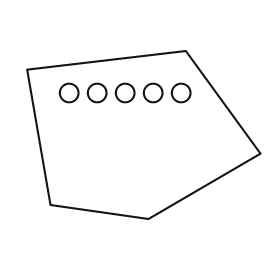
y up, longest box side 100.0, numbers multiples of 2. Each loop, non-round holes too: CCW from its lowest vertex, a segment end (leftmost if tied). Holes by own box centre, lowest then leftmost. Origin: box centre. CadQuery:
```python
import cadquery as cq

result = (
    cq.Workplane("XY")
    .moveTo(2.0, -36.0)
    .lineTo(50.0, -8.0)
    .lineTo(18.0, 36.0)
    .lineTo(-50.0, 28.0)
    .lineTo(-40.0, -30.0)
    .close()
    .moveTo(-32.0, 18.0)
    .circle(4.0)
    .moveTo(-20.0, 18.0)
    .circle(4.0)
    .moveTo(-8.0, 18.0)
    .circle(4.0)
    .moveTo(4.0, 18.0)
    .circle(4.0)
    .moveTo(16.0, 18.0)
    .circle(4.0)
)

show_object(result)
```